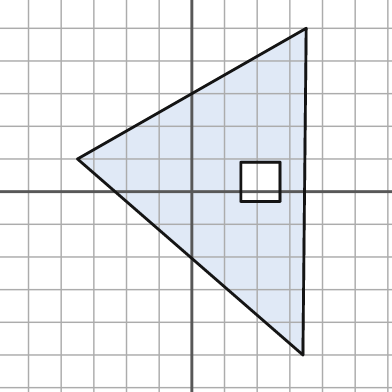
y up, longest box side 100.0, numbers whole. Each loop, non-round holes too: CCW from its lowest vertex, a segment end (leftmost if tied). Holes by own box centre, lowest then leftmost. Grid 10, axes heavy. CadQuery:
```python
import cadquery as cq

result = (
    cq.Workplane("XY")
    .moveTo(34.0, -50.0)
    .lineTo(35.0, 50.0)
    .lineTo(-35.0, 10.0)
    .close()
    .moveTo(15.0, -3.0)
    .lineTo(27.0, -3.0)
    .lineTo(27.0, 9.0)
    .lineTo(15.0, 9.0)
    .close()
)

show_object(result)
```